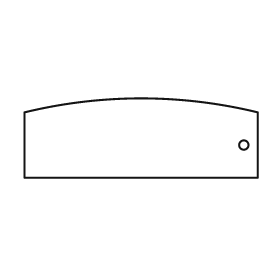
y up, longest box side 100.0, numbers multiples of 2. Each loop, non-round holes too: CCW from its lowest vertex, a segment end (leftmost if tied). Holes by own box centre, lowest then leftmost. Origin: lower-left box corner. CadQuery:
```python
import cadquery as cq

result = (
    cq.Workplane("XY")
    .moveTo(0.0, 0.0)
    .lineTo(100.0, 0.0)
    .lineTo(100.0, 28.0)
    .threePointArc((50.0, 34.0), (0.0, 28.0))
    .close()
    .moveTo(94.0, 14.0)
    .circle(2.0)
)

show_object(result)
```